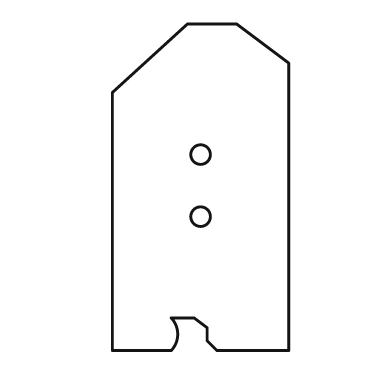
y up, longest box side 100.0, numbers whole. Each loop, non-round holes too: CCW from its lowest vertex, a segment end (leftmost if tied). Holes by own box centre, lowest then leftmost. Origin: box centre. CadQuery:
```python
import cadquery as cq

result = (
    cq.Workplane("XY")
    .moveTo(-27.0, -50.0)
    .lineTo(-9.0, -50.0)
    .threePointArc((-7.0, -45.0), (-9.0, -40.0))
    .lineTo(-2.0, -40.0)
    .lineTo(2.0, -43.0)
    .lineTo(2.0, -47.0)
    .lineTo(5.0, -50.0)
    .lineTo(27.0, -50.0)
    .lineTo(27.0, 38.0)
    .lineTo(11.0, 50.0)
    .lineTo(-4.0, 50.0)
    .lineTo(-27.0, 29.0)
    .close()
    .moveTo(0.0, -9.0)
    .circle(3.0)
    .moveTo(0.0, 10.0)
    .circle(3.0)
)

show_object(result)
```